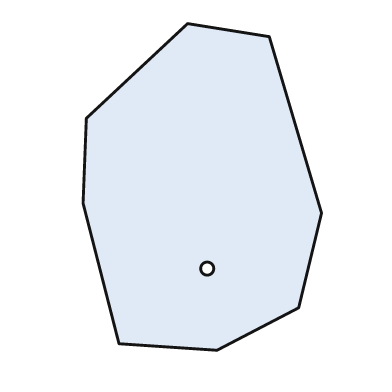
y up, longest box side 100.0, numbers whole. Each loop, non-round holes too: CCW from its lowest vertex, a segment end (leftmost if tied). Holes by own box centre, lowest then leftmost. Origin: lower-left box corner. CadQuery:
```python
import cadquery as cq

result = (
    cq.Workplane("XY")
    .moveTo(41.0, 0.0)
    .lineTo(66.0, 13.0)
    .lineTo(73.0, 42.0)
    .lineTo(57.0, 96.0)
    .lineTo(32.0, 100.0)
    .lineTo(1.0, 71.0)
    .lineTo(0.0, 45.0)
    .lineTo(11.0, 2.0)
    .close()
    .moveTo(38.0, 25.0)
    .circle(2.0)
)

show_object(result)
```